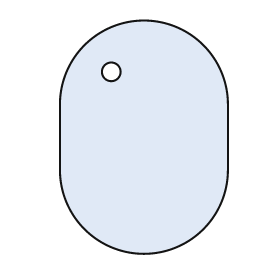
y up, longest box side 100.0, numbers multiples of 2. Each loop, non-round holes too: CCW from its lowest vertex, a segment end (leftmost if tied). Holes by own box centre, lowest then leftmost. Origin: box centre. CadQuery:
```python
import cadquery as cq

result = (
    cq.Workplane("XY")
    .moveTo(-36.0, -14.0)
    .threePointArc((0.0, -50.0), (36.0, -14.0))
    .lineTo(36.0, 14.0)
    .threePointArc((0.0, 50.0), (-36.0, 14.0))
    .close()
    .moveTo(-14.0, 28.0)
    .circle(4.0)
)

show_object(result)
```